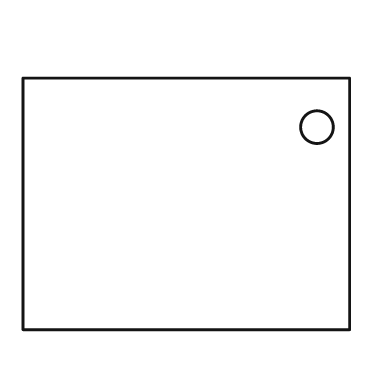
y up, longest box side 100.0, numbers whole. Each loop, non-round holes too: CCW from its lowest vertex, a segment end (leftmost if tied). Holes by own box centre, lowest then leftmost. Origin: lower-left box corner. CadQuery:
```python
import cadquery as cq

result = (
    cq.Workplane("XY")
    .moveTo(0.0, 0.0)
    .lineTo(100.0, 0.0)
    .lineTo(100.0, 77.0)
    .lineTo(0.0, 77.0)
    .close()
    .moveTo(90.0, 62.0)
    .circle(5.0)
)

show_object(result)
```